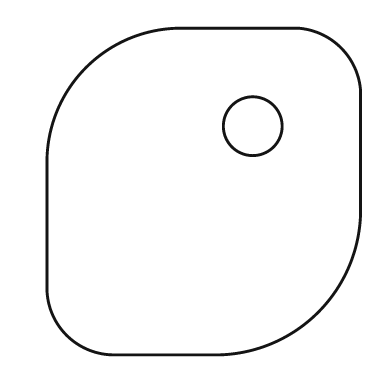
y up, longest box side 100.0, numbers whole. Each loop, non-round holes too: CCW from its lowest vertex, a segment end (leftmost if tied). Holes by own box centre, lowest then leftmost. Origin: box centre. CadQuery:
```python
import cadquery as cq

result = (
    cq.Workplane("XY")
    .moveTo(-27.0, -50.0)
    .lineTo(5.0, -50.0)
    .threePointArc((35.0, -37.0), (48.0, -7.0))
    .lineTo(48.0, 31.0)
    .threePointArc((42.0, 44.0), (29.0, 50.0))
    .lineTo(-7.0, 50.0)
    .threePointArc((-36.0, 38.0), (-48.0, 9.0))
    .lineTo(-48.0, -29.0)
    .threePointArc((-42.0, -44.0), (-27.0, -50.0))
    .close()
    .moveTo(15.0, 20.0)
    .circle(9.0)
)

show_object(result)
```